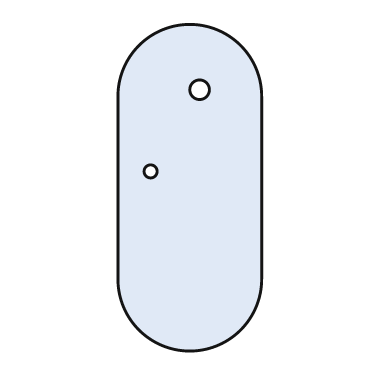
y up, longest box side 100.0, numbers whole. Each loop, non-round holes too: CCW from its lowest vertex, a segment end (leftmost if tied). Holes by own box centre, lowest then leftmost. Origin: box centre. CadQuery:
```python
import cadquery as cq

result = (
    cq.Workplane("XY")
    .moveTo(-22.0, -28.0)
    .threePointArc((0.0, -50.0), (22.0, -28.0))
    .lineTo(22.0, 28.0)
    .threePointArc((0.0, 50.0), (-22.0, 28.0))
    .close()
    .moveTo(-12.0, 5.0)
    .circle(2.0)
    .moveTo(3.0, 30.0)
    .circle(3.0)
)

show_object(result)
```